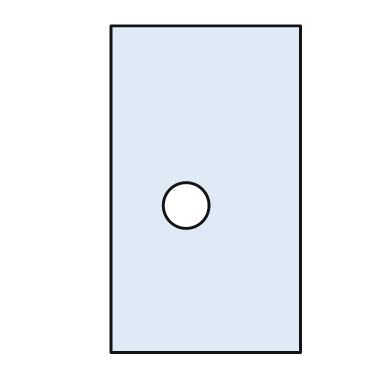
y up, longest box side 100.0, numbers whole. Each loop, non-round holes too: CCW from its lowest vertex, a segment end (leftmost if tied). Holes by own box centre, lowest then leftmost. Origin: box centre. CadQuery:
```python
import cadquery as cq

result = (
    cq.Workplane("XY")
    .moveTo(-29.0, -50.0)
    .lineTo(29.0, -50.0)
    .lineTo(29.0, 50.0)
    .lineTo(-29.0, 50.0)
    .close()
    .moveTo(-6.0, -5.0)
    .circle(7.0)
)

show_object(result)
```